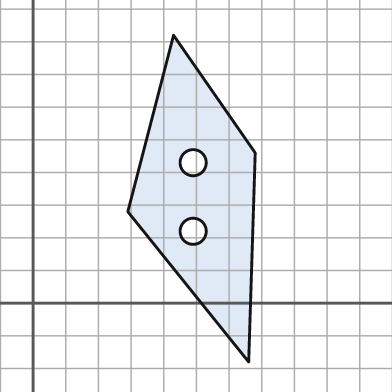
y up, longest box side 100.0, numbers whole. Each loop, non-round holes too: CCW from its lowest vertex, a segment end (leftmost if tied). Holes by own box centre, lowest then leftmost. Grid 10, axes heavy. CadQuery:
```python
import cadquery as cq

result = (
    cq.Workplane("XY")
    .moveTo(66.0, -18.0)
    .lineTo(68.0, 46.0)
    .lineTo(43.0, 82.0)
    .lineTo(29.0, 28.0)
    .close()
    .moveTo(49.0, 22.0)
    .circle(4.0)
    .moveTo(49.0, 43.0)
    .circle(4.0)
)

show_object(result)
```